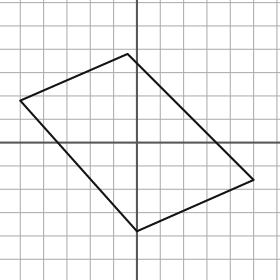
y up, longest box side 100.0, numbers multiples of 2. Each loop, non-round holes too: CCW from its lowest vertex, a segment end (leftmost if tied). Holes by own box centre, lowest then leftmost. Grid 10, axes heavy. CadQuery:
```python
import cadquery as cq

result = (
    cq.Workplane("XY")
    .moveTo(0.0, -38.0)
    .lineTo(50.0, -16.0)
    .lineTo(-4.0, 38.0)
    .lineTo(-50.0, 18.0)
    .close()
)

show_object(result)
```